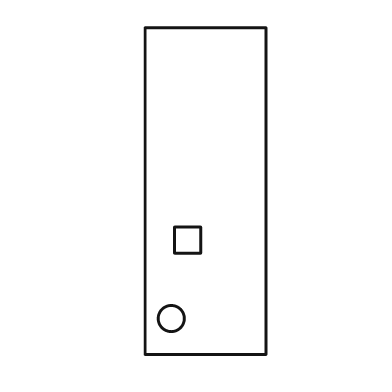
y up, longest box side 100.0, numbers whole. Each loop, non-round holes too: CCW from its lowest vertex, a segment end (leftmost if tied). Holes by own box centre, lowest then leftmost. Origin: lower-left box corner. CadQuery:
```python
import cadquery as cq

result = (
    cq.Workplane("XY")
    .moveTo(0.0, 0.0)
    .lineTo(37.0, 0.0)
    .lineTo(37.0, 100.0)
    .lineTo(0.0, 100.0)
    .close()
    .moveTo(8.0, 11.0)
    .circle(4.0)
    .moveTo(9.0, 31.0)
    .lineTo(17.0, 31.0)
    .lineTo(17.0, 39.0)
    .lineTo(9.0, 39.0)
    .close()
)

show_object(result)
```